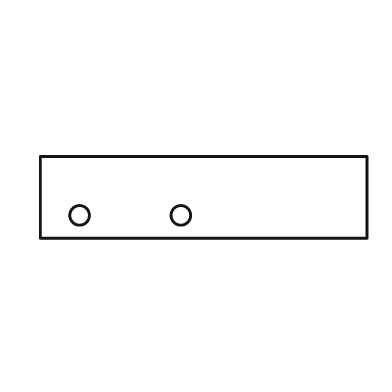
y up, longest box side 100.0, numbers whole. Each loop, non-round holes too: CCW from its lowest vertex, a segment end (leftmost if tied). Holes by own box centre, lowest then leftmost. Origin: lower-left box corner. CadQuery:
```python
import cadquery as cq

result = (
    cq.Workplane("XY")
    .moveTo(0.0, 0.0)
    .lineTo(100.0, 0.0)
    .lineTo(100.0, 25.0)
    .lineTo(0.0, 25.0)
    .close()
    .moveTo(12.0, 7.0)
    .circle(3.0)
    .moveTo(43.0, 7.0)
    .circle(3.0)
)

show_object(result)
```